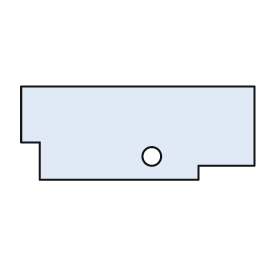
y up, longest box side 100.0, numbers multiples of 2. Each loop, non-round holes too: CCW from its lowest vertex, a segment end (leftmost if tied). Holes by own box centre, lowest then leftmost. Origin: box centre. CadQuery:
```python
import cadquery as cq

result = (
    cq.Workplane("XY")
    .moveTo(-42.0, -20.0)
    .lineTo(26.0, -20.0)
    .lineTo(26.0, -14.0)
    .lineTo(50.0, -14.0)
    .lineTo(50.0, 20.0)
    .lineTo(-50.0, 20.0)
    .lineTo(-50.0, -4.0)
    .lineTo(-42.0, -4.0)
    .close()
    .moveTo(6.0, -10.0)
    .circle(4.0)
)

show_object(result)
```